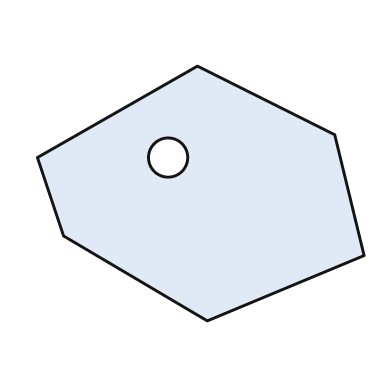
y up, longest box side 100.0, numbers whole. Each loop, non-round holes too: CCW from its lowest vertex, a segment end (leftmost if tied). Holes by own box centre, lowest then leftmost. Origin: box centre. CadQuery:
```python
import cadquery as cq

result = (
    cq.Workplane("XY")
    .moveTo(2.0, -39.0)
    .lineTo(50.0, -19.0)
    .lineTo(41.0, 18.0)
    .lineTo(-1.0, 39.0)
    .lineTo(-50.0, 11.0)
    .lineTo(-42.0, -13.0)
    .close()
    .moveTo(-10.0, 11.0)
    .circle(6.0)
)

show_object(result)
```